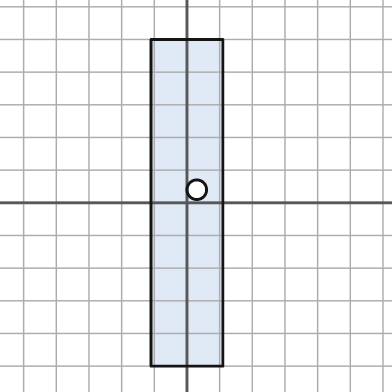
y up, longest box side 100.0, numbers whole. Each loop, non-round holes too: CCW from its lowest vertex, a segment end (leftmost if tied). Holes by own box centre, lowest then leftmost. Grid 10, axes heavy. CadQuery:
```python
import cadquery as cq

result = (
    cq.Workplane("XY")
    .moveTo(-11.0, -50.0)
    .lineTo(11.0, -50.0)
    .lineTo(11.0, 50.0)
    .lineTo(-11.0, 50.0)
    .close()
    .moveTo(3.0, 4.0)
    .circle(3.0)
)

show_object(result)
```